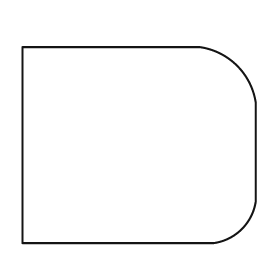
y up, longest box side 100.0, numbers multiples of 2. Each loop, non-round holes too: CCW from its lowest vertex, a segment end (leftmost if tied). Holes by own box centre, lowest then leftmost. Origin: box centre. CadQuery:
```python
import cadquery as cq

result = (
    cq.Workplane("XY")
    .moveTo(-50.0, -42.0)
    .lineTo(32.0, -42.0)
    .threePointArc((44.0, -36.0), (50.0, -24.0))
    .lineTo(50.0, 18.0)
    .threePointArc((42.0, 34.0), (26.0, 42.0))
    .lineTo(-50.0, 42.0)
    .close()
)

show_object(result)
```